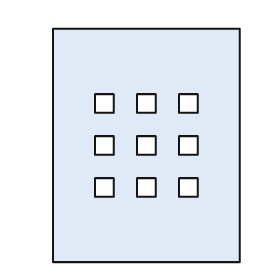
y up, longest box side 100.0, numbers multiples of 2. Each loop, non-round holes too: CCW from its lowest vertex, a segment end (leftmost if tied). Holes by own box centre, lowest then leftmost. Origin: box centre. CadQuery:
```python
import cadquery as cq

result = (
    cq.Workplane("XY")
    .moveTo(-40.0, -50.0)
    .lineTo(40.0, -50.0)
    .lineTo(40.0, 50.0)
    .lineTo(-40.0, 50.0)
    .close()
    .moveTo(-22.0, -22.0)
    .lineTo(-14.0, -22.0)
    .lineTo(-14.0, -14.0)
    .lineTo(-22.0, -14.0)
    .close()
    .moveTo(-4.0, -22.0)
    .lineTo(4.0, -22.0)
    .lineTo(4.0, -14.0)
    .lineTo(-4.0, -14.0)
    .close()
    .moveTo(14.0, -22.0)
    .lineTo(22.0, -22.0)
    .lineTo(22.0, -14.0)
    .lineTo(14.0, -14.0)
    .close()
    .moveTo(-22.0, -4.0)
    .lineTo(-14.0, -4.0)
    .lineTo(-14.0, 4.0)
    .lineTo(-22.0, 4.0)
    .close()
    .moveTo(-4.0, -4.0)
    .lineTo(4.0, -4.0)
    .lineTo(4.0, 4.0)
    .lineTo(-4.0, 4.0)
    .close()
    .moveTo(14.0, -4.0)
    .lineTo(22.0, -4.0)
    .lineTo(22.0, 4.0)
    .lineTo(14.0, 4.0)
    .close()
    .moveTo(-22.0, 14.0)
    .lineTo(-14.0, 14.0)
    .lineTo(-14.0, 22.0)
    .lineTo(-22.0, 22.0)
    .close()
    .moveTo(-4.0, 14.0)
    .lineTo(4.0, 14.0)
    .lineTo(4.0, 22.0)
    .lineTo(-4.0, 22.0)
    .close()
    .moveTo(14.0, 14.0)
    .lineTo(22.0, 14.0)
    .lineTo(22.0, 22.0)
    .lineTo(14.0, 22.0)
    .close()
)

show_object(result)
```